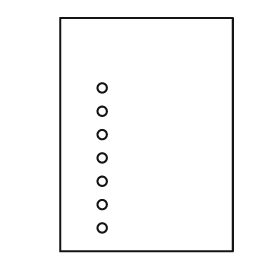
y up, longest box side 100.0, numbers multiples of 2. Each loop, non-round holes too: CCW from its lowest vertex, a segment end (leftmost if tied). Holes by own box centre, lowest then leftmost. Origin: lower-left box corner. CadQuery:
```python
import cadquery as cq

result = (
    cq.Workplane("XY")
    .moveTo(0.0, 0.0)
    .lineTo(74.0, 0.0)
    .lineTo(74.0, 100.0)
    .lineTo(0.0, 100.0)
    .close()
    .moveTo(18.0, 10.0)
    .circle(2.0)
    .moveTo(18.0, 20.0)
    .circle(2.0)
    .moveTo(18.0, 30.0)
    .circle(2.0)
    .moveTo(18.0, 40.0)
    .circle(2.0)
    .moveTo(18.0, 50.0)
    .circle(2.0)
    .moveTo(18.0, 60.0)
    .circle(2.0)
    .moveTo(18.0, 70.0)
    .circle(2.0)
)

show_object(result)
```